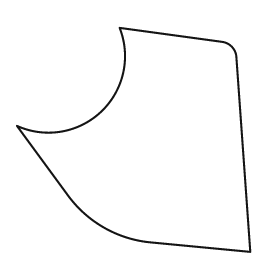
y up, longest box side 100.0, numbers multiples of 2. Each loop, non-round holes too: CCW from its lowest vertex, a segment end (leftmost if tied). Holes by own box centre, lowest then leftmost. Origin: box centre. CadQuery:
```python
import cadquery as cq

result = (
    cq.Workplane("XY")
    .moveTo(50.0, -48.0)
    .lineTo(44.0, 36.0)
    .threePointArc((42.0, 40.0), (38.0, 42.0))
    .lineTo(-6.0, 48.0)
    .threePointArc((-14.0, 12.0), (-50.0, 6.0))
    .lineTo(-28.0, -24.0)
    .threePointArc((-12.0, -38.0), (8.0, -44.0))
    .close()
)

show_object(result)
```